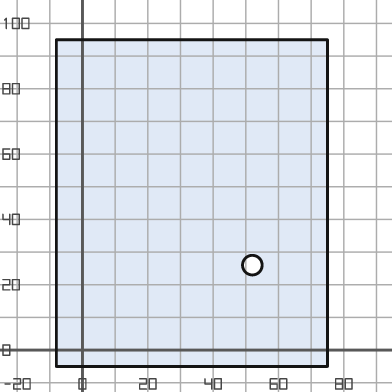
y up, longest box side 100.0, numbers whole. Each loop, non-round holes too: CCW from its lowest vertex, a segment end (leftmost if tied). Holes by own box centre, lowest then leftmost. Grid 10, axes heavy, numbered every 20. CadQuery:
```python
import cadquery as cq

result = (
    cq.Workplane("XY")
    .moveTo(-8.0, -5.0)
    .lineTo(75.0, -5.0)
    .lineTo(75.0, 95.0)
    .lineTo(-8.0, 95.0)
    .close()
    .moveTo(52.0, 26.0)
    .circle(3.0)
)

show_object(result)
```